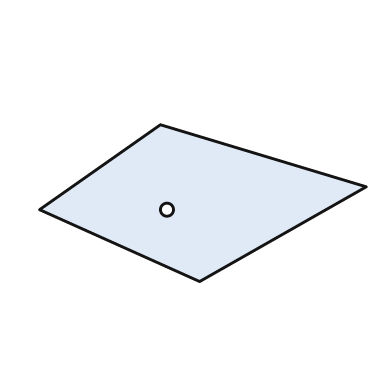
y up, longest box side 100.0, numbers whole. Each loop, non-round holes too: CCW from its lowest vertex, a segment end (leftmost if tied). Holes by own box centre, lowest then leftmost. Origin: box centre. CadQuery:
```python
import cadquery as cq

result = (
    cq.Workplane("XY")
    .moveTo(-1.0, -24.0)
    .lineTo(50.0, 5.0)
    .lineTo(-13.0, 24.0)
    .lineTo(-50.0, -2.0)
    .close()
    .moveTo(-11.0, -2.0)
    .circle(2.0)
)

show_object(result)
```